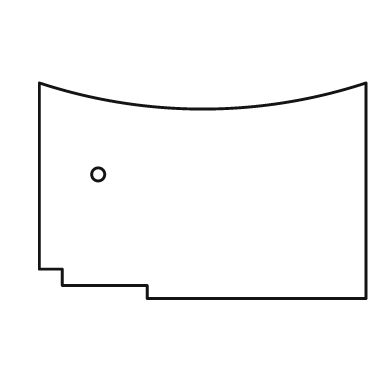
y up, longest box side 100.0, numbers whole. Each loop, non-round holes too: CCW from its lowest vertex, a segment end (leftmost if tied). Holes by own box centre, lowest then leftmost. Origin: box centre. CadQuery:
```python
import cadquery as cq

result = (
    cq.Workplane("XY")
    .moveTo(-17.0, -33.0)
    .lineTo(50.0, -33.0)
    .lineTo(50.0, 33.0)
    .threePointArc((0.0, 25.0), (-50.0, 33.0))
    .lineTo(-50.0, -24.0)
    .lineTo(-43.0, -24.0)
    .lineTo(-43.0, -29.0)
    .lineTo(-17.0, -29.0)
    .close()
    .moveTo(-32.0, 5.0)
    .circle(2.0)
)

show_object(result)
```